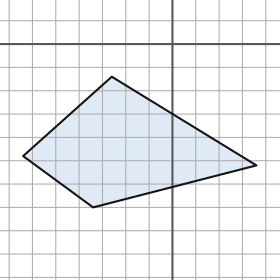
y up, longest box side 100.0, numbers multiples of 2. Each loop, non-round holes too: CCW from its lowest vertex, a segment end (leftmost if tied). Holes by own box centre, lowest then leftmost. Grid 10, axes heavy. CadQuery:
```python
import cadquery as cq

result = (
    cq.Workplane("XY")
    .moveTo(-34.0, -70.0)
    .lineTo(36.0, -52.0)
    .lineTo(-26.0, -14.0)
    .lineTo(-64.0, -48.0)
    .close()
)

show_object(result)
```